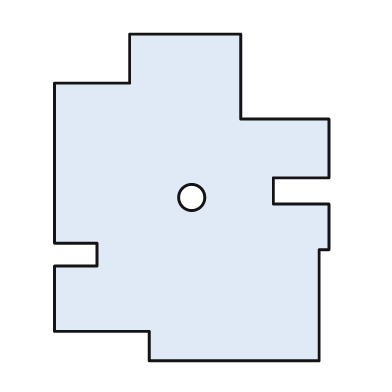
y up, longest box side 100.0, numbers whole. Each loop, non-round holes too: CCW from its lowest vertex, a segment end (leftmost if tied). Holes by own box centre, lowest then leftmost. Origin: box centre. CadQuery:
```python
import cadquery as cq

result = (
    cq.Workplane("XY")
    .moveTo(-13.0, -50.0)
    .lineTo(39.0, -50.0)
    .lineTo(39.0, -16.0)
    .lineTo(42.0, -16.0)
    .lineTo(42.0, -2.0)
    .lineTo(25.0, -2.0)
    .lineTo(25.0, 6.0)
    .lineTo(42.0, 6.0)
    .lineTo(42.0, 24.0)
    .lineTo(15.0, 24.0)
    .lineTo(15.0, 50.0)
    .lineTo(-19.0, 50.0)
    .lineTo(-19.0, 35.0)
    .lineTo(-42.0, 35.0)
    .lineTo(-42.0, -14.0)
    .lineTo(-29.0, -14.0)
    .lineTo(-29.0, -21.0)
    .lineTo(-42.0, -21.0)
    .lineTo(-42.0, -41.0)
    .lineTo(-13.0, -41.0)
    .close()
    .moveTo(0.0, 0.0)
    .circle(4.0)
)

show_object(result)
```